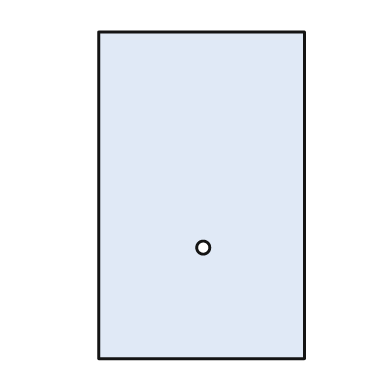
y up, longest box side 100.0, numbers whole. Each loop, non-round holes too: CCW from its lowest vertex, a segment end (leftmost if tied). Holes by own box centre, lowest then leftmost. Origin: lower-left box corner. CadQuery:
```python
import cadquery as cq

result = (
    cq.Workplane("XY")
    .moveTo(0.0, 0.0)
    .lineTo(63.0, 0.0)
    .lineTo(63.0, 100.0)
    .lineTo(0.0, 100.0)
    .close()
    .moveTo(32.0, 34.0)
    .circle(2.0)
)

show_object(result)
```